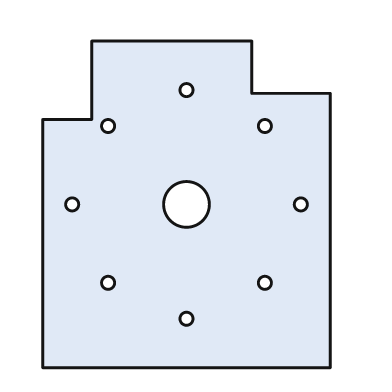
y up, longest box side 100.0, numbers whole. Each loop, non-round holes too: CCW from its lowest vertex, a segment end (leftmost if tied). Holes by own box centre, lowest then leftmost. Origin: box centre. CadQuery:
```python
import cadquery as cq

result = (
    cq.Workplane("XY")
    .moveTo(-44.0, -50.0)
    .lineTo(44.0, -50.0)
    .lineTo(44.0, 34.0)
    .lineTo(20.0, 34.0)
    .lineTo(20.0, 50.0)
    .lineTo(-29.0, 50.0)
    .lineTo(-29.0, 26.0)
    .lineTo(-44.0, 26.0)
    .close()
    .moveTo(0.0, -35.0)
    .circle(2.0)
    .moveTo(-24.0, -24.0)
    .circle(2.0)
    .moveTo(24.0, -24.0)
    .circle(2.0)
    .moveTo(-35.0, 0.0)
    .circle(2.0)
    .moveTo(0.0, 0.0)
    .circle(7.0)
    .moveTo(35.0, 0.0)
    .circle(2.0)
    .moveTo(-24.0, 24.0)
    .circle(2.0)
    .moveTo(24.0, 24.0)
    .circle(2.0)
    .moveTo(0.0, 35.0)
    .circle(2.0)
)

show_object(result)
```